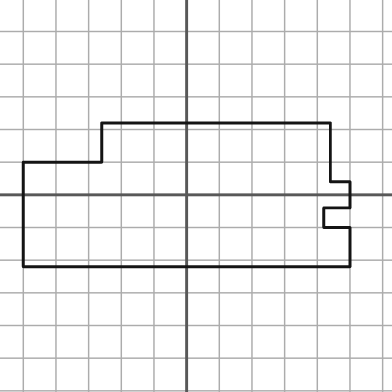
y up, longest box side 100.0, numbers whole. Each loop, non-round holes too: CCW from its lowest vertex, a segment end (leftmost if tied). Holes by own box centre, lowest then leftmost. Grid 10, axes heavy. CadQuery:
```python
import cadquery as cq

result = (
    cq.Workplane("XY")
    .moveTo(-50.0, -22.0)
    .lineTo(50.0, -22.0)
    .lineTo(50.0, -10.0)
    .lineTo(42.0, -10.0)
    .lineTo(42.0, -4.0)
    .lineTo(50.0, -4.0)
    .lineTo(50.0, 4.0)
    .lineTo(44.0, 4.0)
    .lineTo(44.0, 22.0)
    .lineTo(-26.0, 22.0)
    .lineTo(-26.0, 10.0)
    .lineTo(-50.0, 10.0)
    .close()
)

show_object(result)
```